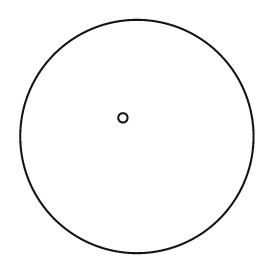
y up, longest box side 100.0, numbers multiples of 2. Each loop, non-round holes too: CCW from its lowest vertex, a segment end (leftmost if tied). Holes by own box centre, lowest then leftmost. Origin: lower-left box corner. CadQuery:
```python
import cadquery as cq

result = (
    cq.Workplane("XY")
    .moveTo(50.0, 50.0)
    .circle(50.0)
    .moveTo(44.0, 58.0)
    .circle(2.0)
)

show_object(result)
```